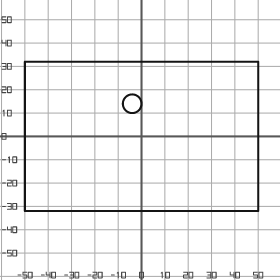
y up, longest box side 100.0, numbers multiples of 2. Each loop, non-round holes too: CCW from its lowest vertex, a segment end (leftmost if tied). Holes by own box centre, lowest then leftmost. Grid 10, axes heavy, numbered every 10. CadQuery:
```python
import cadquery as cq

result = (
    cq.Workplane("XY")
    .moveTo(-50.0, -32.0)
    .lineTo(50.0, -32.0)
    .lineTo(50.0, 32.0)
    .lineTo(-50.0, 32.0)
    .close()
    .moveTo(-4.0, 14.0)
    .circle(4.0)
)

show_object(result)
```